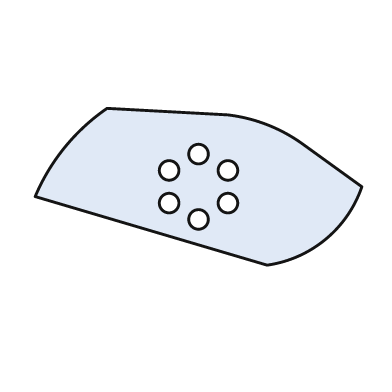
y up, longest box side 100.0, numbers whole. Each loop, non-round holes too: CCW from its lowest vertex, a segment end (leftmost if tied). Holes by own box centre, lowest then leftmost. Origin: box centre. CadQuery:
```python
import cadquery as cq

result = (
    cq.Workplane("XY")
    .moveTo(21.0, -24.0)
    .threePointArc((39.0, -16.0), (50.0, 0.0))
    .lineTo(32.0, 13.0)
    .threePointArc((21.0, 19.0), (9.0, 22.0))
    .lineTo(-28.0, 24.0)
    .threePointArc((-41.0, 12.0), (-50.0, -3.0))
    .close()
    .moveTo(0.0, -10.0)
    .circle(3.0)
    .moveTo(-9.0, -5.0)
    .circle(3.0)
    .moveTo(9.0, -5.0)
    .circle(3.0)
    .moveTo(-9.0, 5.0)
    .circle(3.0)
    .moveTo(9.0, 5.0)
    .circle(3.0)
    .moveTo(0.0, 10.0)
    .circle(3.0)
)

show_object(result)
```